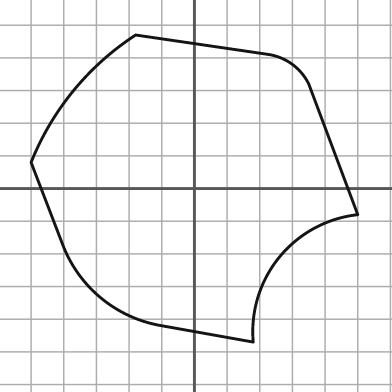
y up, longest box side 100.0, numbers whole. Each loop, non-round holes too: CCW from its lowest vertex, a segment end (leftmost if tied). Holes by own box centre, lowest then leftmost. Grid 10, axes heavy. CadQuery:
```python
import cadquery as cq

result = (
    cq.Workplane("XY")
    .moveTo(18.0, -47.0)
    .threePointArc((26.0, -21.0), (50.0, -8.0))
    .lineTo(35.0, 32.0)
    .threePointArc((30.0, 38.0), (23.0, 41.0))
    .lineTo(-18.0, 47.0)
    .threePointArc((-37.0, 30.0), (-50.0, 8.0))
    .lineTo(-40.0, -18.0)
    .threePointArc((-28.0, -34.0), (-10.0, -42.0))
    .close()
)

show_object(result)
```